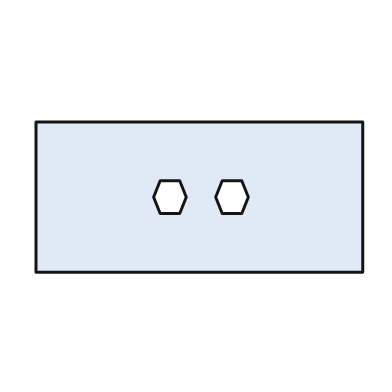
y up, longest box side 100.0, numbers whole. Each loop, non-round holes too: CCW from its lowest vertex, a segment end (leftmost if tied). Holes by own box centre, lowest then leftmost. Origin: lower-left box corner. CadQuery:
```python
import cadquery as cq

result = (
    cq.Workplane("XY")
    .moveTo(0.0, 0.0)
    .lineTo(100.0, 0.0)
    .lineTo(100.0, 46.0)
    .lineTo(0.0, 46.0)
    .close()
    .moveTo(38.0, 18.0)
    .lineTo(44.0, 18.0)
    .lineTo(46.0, 23.0)
    .lineTo(44.0, 28.0)
    .lineTo(38.0, 28.0)
    .lineTo(36.0, 23.0)
    .close()
    .moveTo(57.0, 18.0)
    .lineTo(63.0, 18.0)
    .lineTo(65.0, 23.0)
    .lineTo(63.0, 28.0)
    .lineTo(57.0, 28.0)
    .lineTo(55.0, 23.0)
    .close()
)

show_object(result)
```